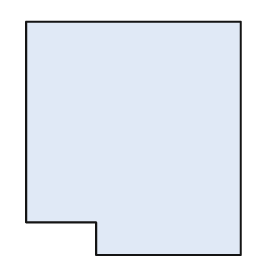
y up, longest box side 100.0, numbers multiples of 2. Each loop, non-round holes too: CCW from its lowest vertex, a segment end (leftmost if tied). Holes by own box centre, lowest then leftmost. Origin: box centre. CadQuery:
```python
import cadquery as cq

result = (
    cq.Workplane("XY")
    .moveTo(-16.0, -50.0)
    .lineTo(46.0, -50.0)
    .lineTo(46.0, 50.0)
    .lineTo(-46.0, 50.0)
    .lineTo(-46.0, -36.0)
    .lineTo(-16.0, -36.0)
    .close()
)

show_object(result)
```